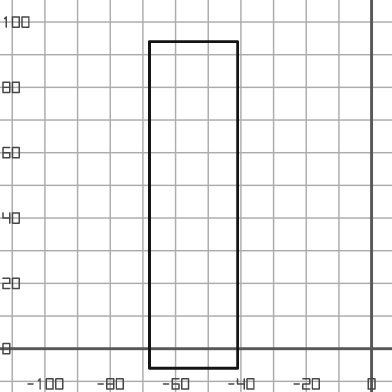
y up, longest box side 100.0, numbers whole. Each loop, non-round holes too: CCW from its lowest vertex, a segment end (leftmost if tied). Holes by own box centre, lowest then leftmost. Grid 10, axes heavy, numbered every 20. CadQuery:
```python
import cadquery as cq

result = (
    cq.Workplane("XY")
    .moveTo(-68.0, -6.0)
    .lineTo(-41.0, -6.0)
    .lineTo(-41.0, 94.0)
    .lineTo(-68.0, 94.0)
    .close()
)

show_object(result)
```